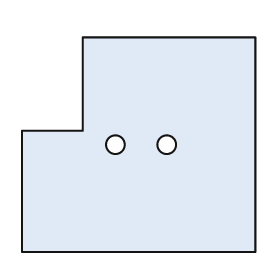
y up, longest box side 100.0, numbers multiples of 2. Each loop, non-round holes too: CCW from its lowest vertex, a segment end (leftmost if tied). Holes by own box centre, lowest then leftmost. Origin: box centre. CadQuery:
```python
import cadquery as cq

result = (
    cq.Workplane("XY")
    .moveTo(-50.0, -46.0)
    .lineTo(50.0, -46.0)
    .lineTo(50.0, 46.0)
    .lineTo(-24.0, 46.0)
    .lineTo(-24.0, 6.0)
    .lineTo(-50.0, 6.0)
    .close()
    .moveTo(-10.0, 0.0)
    .circle(4.0)
    .moveTo(12.0, 0.0)
    .circle(4.0)
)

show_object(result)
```